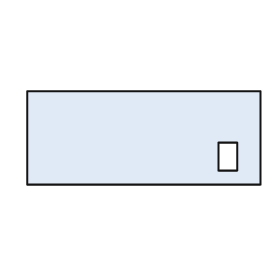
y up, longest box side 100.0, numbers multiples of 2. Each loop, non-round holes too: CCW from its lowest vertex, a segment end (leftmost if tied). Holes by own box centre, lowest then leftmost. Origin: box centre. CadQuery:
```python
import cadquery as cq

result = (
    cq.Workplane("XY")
    .moveTo(-50.0, -20.0)
    .lineTo(50.0, -20.0)
    .lineTo(50.0, 20.0)
    .lineTo(-50.0, 20.0)
    .close()
    .moveTo(32.0, -14.0)
    .lineTo(40.0, -14.0)
    .lineTo(40.0, -2.0)
    .lineTo(32.0, -2.0)
    .close()
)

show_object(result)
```